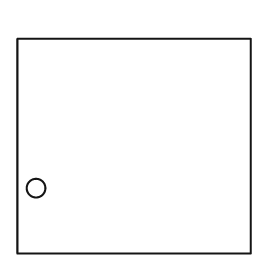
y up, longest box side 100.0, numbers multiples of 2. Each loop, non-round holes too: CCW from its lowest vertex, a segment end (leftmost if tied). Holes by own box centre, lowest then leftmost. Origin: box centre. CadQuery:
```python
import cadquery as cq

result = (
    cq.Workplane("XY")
    .moveTo(-50.0, -46.0)
    .lineTo(50.0, -46.0)
    .lineTo(50.0, 46.0)
    .lineTo(-50.0, 46.0)
    .close()
    .moveTo(-42.0, -18.0)
    .circle(4.0)
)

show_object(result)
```